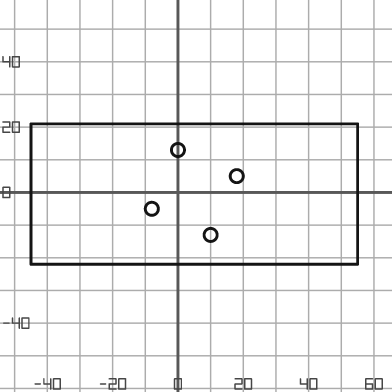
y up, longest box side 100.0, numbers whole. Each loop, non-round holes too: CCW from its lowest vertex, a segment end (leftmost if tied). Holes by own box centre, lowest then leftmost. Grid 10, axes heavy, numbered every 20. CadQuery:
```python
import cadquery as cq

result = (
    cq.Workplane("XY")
    .moveTo(-45.0, -22.0)
    .lineTo(55.0, -22.0)
    .lineTo(55.0, 21.0)
    .lineTo(-45.0, 21.0)
    .close()
    .moveTo(10.0, -13.0)
    .circle(2.0)
    .moveTo(-8.0, -5.0)
    .circle(2.0)
    .moveTo(18.0, 5.0)
    .circle(2.0)
    .moveTo(0.0, 13.0)
    .circle(2.0)
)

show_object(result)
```